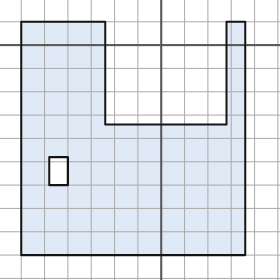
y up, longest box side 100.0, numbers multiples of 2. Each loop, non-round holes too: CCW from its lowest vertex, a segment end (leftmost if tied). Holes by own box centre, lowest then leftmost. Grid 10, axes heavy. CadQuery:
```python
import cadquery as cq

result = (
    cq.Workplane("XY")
    .moveTo(-60.0, -90.0)
    .lineTo(36.0, -90.0)
    .lineTo(36.0, 10.0)
    .lineTo(28.0, 10.0)
    .lineTo(28.0, -34.0)
    .lineTo(-24.0, -34.0)
    .lineTo(-24.0, 10.0)
    .lineTo(-60.0, 10.0)
    .close()
    .moveTo(-48.0, -60.0)
    .lineTo(-40.0, -60.0)
    .lineTo(-40.0, -48.0)
    .lineTo(-48.0, -48.0)
    .close()
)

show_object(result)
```